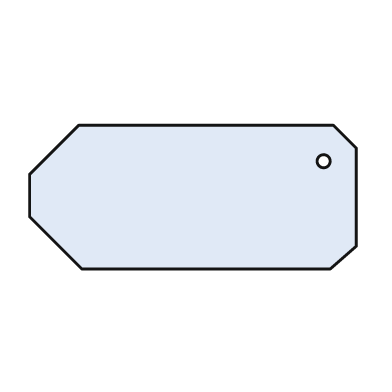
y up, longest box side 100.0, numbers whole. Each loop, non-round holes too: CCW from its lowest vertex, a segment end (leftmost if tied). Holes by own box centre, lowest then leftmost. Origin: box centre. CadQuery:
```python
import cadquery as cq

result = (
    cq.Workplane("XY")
    .moveTo(-34.0, -22.0)
    .lineTo(42.0, -22.0)
    .lineTo(50.0, -15.0)
    .lineTo(50.0, 15.0)
    .lineTo(43.0, 22.0)
    .lineTo(-35.0, 22.0)
    .lineTo(-50.0, 7.0)
    .lineTo(-50.0, -6.0)
    .close()
    .moveTo(40.0, 11.0)
    .circle(2.0)
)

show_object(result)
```